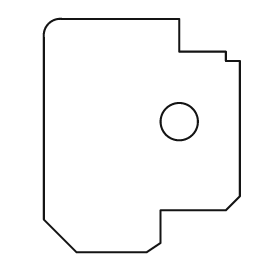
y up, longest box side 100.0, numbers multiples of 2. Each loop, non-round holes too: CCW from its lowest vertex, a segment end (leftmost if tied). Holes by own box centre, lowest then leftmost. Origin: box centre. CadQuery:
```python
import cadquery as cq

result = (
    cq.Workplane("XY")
    .moveTo(-28.0, -50.0)
    .lineTo(2.0, -50.0)
    .lineTo(8.0, -46.0)
    .lineTo(8.0, -32.0)
    .lineTo(36.0, -32.0)
    .lineTo(42.0, -26.0)
    .lineTo(42.0, 32.0)
    .lineTo(36.0, 32.0)
    .lineTo(36.0, 36.0)
    .lineTo(16.0, 36.0)
    .lineTo(16.0, 50.0)
    .lineTo(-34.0, 50.0)
    .threePointArc((-40.0, 48.0), (-42.0, 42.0))
    .lineTo(-42.0, -36.0)
    .close()
    .moveTo(16.0, 6.0)
    .circle(8.0)
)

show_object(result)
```